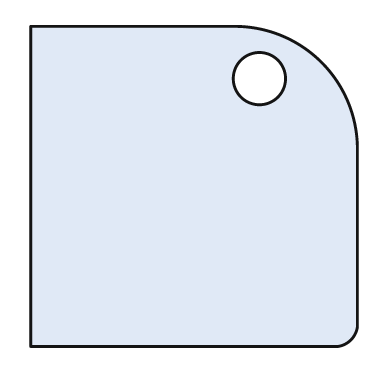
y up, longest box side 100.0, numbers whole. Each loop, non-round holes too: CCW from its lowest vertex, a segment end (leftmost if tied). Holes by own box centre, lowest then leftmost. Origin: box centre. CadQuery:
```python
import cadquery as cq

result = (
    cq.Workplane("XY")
    .moveTo(-50.0, -49.0)
    .lineTo(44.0, -49.0)
    .threePointArc((48.0, -47.0), (50.0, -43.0))
    .lineTo(50.0, 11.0)
    .threePointArc((39.0, 38.0), (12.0, 49.0))
    .lineTo(-50.0, 49.0)
    .close()
    .moveTo(20.0, 33.0)
    .circle(8.0)
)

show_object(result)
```